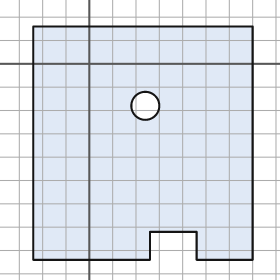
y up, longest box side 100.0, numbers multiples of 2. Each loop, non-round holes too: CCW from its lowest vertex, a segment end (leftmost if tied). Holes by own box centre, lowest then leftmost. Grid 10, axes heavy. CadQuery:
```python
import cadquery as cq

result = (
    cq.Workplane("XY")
    .moveTo(-24.0, -84.0)
    .lineTo(26.0, -84.0)
    .lineTo(26.0, -72.0)
    .lineTo(46.0, -72.0)
    .lineTo(46.0, -84.0)
    .lineTo(70.0, -84.0)
    .lineTo(70.0, 16.0)
    .lineTo(-24.0, 16.0)
    .close()
    .moveTo(24.0, -18.0)
    .circle(6.0)
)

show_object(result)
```